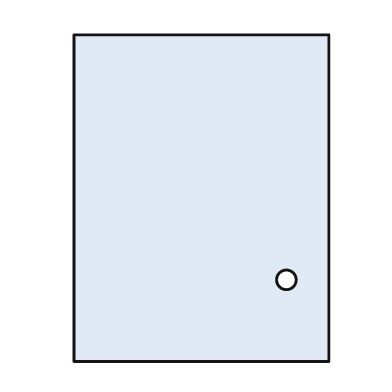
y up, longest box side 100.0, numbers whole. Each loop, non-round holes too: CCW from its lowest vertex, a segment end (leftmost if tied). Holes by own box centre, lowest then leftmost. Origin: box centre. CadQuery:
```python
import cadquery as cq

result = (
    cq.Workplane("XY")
    .moveTo(-39.0, -50.0)
    .lineTo(39.0, -50.0)
    .lineTo(39.0, 50.0)
    .lineTo(-39.0, 50.0)
    .close()
    .moveTo(26.0, -25.0)
    .circle(3.0)
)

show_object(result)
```